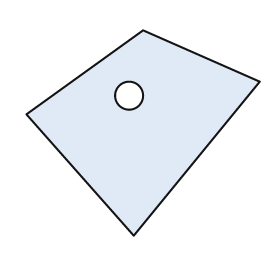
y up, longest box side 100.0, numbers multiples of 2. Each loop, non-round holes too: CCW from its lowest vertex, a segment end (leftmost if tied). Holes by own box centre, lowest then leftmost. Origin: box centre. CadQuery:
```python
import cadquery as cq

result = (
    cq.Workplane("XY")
    .moveTo(-4.0, -44.0)
    .lineTo(50.0, 22.0)
    .lineTo(0.0, 44.0)
    .lineTo(-50.0, 8.0)
    .close()
    .moveTo(-6.0, 16.0)
    .circle(6.0)
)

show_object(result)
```